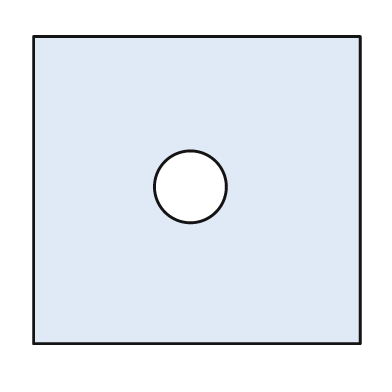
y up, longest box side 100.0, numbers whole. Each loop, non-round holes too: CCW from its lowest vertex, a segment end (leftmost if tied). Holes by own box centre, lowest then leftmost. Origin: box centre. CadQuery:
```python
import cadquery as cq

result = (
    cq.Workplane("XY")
    .moveTo(-50.0, -47.0)
    .lineTo(50.0, -47.0)
    .lineTo(50.0, 47.0)
    .lineTo(-50.0, 47.0)
    .close()
    .moveTo(-2.0, 1.0)
    .circle(11.0)
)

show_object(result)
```